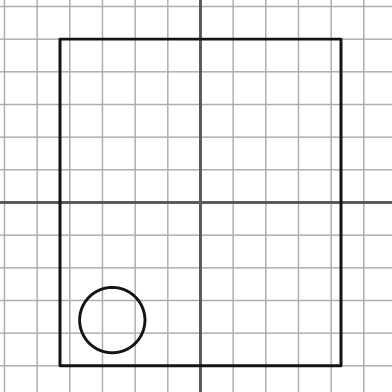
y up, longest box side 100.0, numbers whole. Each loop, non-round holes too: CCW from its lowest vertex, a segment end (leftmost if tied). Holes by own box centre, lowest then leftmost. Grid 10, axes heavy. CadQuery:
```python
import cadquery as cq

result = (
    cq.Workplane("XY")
    .moveTo(-43.0, -50.0)
    .lineTo(43.0, -50.0)
    .lineTo(43.0, 50.0)
    .lineTo(-43.0, 50.0)
    .close()
    .moveTo(-27.0, -36.0)
    .circle(10.0)
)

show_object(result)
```